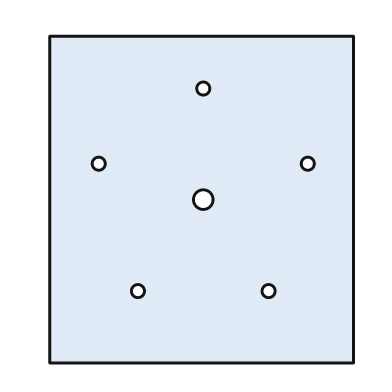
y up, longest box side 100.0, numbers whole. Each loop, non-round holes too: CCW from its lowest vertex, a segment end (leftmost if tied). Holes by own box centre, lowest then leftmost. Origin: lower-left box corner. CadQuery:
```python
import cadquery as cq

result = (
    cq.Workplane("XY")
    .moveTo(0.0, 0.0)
    .lineTo(93.0, 0.0)
    .lineTo(93.0, 100.0)
    .lineTo(0.0, 100.0)
    .close()
    .moveTo(27.0, 22.0)
    .circle(2.0)
    .moveTo(67.0, 22.0)
    .circle(2.0)
    .moveTo(47.0, 50.0)
    .circle(3.0)
    .moveTo(15.0, 61.0)
    .circle(2.0)
    .moveTo(79.0, 61.0)
    .circle(2.0)
    .moveTo(47.0, 84.0)
    .circle(2.0)
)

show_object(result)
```